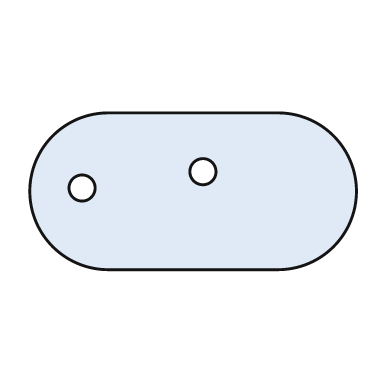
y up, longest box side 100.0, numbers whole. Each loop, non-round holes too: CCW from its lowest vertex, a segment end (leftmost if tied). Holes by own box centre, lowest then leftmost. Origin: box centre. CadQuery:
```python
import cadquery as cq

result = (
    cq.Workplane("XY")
    .moveTo(-26.0, -24.0)
    .lineTo(26.0, -24.0)
    .threePointArc((50.0, 0.0), (26.0, 24.0))
    .lineTo(-26.0, 24.0)
    .threePointArc((-50.0, 0.0), (-26.0, -24.0))
    .close()
    .moveTo(-34.0, 1.0)
    .circle(4.0)
    .moveTo(3.0, 6.0)
    .circle(4.0)
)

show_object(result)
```